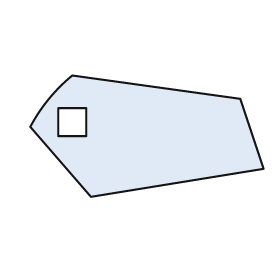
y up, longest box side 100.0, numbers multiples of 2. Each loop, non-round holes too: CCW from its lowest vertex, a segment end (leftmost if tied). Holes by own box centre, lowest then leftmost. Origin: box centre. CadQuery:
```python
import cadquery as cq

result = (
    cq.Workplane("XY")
    .moveTo(-24.0, -26.0)
    .lineTo(50.0, -14.0)
    .lineTo(40.0, 16.0)
    .lineTo(-32.0, 26.0)
    .threePointArc((-42.0, 16.0), (-50.0, 4.0))
    .close()
    .moveTo(-38.0, 0.0)
    .lineTo(-26.0, 0.0)
    .lineTo(-26.0, 12.0)
    .lineTo(-38.0, 12.0)
    .close()
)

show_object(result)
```